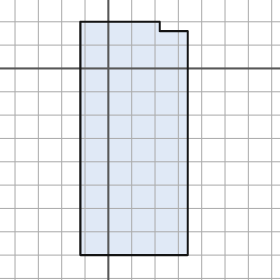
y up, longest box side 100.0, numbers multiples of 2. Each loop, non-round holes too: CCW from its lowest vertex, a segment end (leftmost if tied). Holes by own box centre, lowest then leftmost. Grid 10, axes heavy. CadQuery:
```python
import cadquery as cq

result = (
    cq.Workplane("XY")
    .moveTo(-12.0, -80.0)
    .lineTo(34.0, -80.0)
    .lineTo(34.0, 16.0)
    .lineTo(22.0, 16.0)
    .lineTo(22.0, 20.0)
    .lineTo(-12.0, 20.0)
    .close()
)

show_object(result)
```